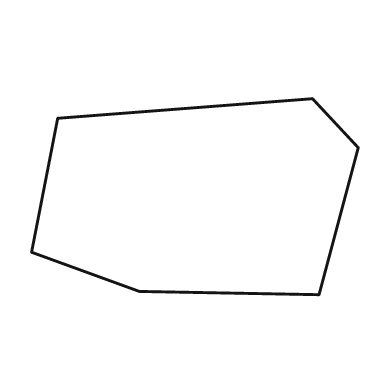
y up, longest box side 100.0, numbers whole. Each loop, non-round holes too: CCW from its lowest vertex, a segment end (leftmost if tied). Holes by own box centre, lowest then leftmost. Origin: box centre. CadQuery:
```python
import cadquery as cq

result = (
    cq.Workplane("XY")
    .moveTo(38.0, -30.0)
    .lineTo(50.0, 15.0)
    .lineTo(36.0, 30.0)
    .lineTo(-42.0, 24.0)
    .lineTo(-50.0, -17.0)
    .lineTo(-17.0, -29.0)
    .close()
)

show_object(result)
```